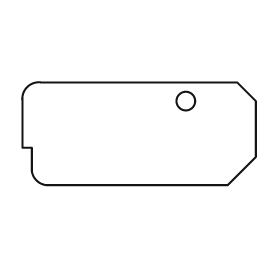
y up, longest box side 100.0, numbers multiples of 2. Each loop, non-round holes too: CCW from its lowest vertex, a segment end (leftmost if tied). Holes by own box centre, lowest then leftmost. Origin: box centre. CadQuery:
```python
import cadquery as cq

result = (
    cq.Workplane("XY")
    .moveTo(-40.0, -22.0)
    .lineTo(38.0, -22.0)
    .lineTo(50.0, -10.0)
    .lineTo(50.0, 14.0)
    .lineTo(42.0, 22.0)
    .lineTo(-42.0, 22.0)
    .threePointArc((-48.0, 20.0), (-50.0, 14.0))
    .lineTo(-50.0, -6.0)
    .lineTo(-46.0, -6.0)
    .lineTo(-46.0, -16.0)
    .threePointArc((-44.0, -20.0), (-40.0, -22.0))
    .close()
    .moveTo(20.0, 14.0)
    .circle(4.0)
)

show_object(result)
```